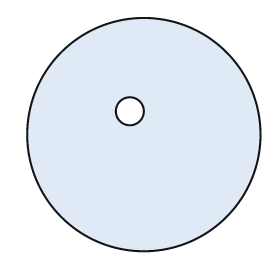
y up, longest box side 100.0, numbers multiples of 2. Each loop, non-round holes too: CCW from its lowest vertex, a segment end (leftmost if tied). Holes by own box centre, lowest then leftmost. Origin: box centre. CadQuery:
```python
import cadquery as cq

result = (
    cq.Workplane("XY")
    .moveTo(0.0, 0.0)
    .circle(50.0)
    .moveTo(-6.0, 10.0)
    .circle(6.0)
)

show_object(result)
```